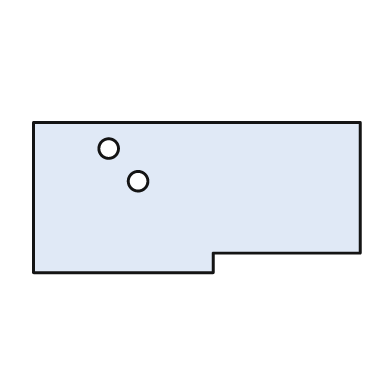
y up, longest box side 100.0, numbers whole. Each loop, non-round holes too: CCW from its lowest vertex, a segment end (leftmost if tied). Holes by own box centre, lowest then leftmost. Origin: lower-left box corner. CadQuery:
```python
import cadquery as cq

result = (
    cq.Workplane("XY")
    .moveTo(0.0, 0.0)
    .lineTo(55.0, 0.0)
    .lineTo(55.0, 6.0)
    .lineTo(100.0, 6.0)
    .lineTo(100.0, 46.0)
    .lineTo(0.0, 46.0)
    .close()
    .moveTo(32.0, 28.0)
    .circle(3.0)
    .moveTo(23.0, 38.0)
    .circle(3.0)
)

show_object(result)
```